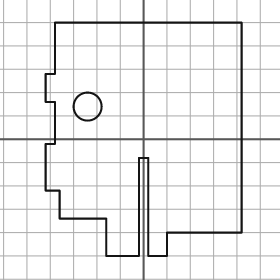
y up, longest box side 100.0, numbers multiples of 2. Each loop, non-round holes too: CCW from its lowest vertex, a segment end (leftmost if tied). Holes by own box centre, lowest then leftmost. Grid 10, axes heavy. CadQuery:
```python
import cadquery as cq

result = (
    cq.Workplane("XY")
    .moveTo(-16.0, -50.0)
    .lineTo(-2.0, -50.0)
    .lineTo(-2.0, -8.0)
    .lineTo(2.0, -8.0)
    .lineTo(2.0, -50.0)
    .lineTo(10.0, -50.0)
    .lineTo(10.0, -40.0)
    .lineTo(42.0, -40.0)
    .lineTo(42.0, 50.0)
    .lineTo(-38.0, 50.0)
    .lineTo(-38.0, 28.0)
    .lineTo(-42.0, 28.0)
    .lineTo(-42.0, 16.0)
    .lineTo(-38.0, 16.0)
    .lineTo(-38.0, -2.0)
    .lineTo(-42.0, -2.0)
    .lineTo(-42.0, -22.0)
    .lineTo(-36.0, -22.0)
    .lineTo(-36.0, -34.0)
    .lineTo(-16.0, -34.0)
    .close()
    .moveTo(-24.0, 14.0)
    .circle(6.0)
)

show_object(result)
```